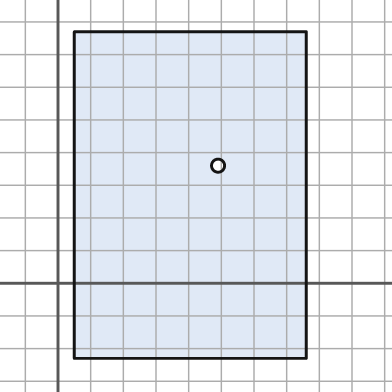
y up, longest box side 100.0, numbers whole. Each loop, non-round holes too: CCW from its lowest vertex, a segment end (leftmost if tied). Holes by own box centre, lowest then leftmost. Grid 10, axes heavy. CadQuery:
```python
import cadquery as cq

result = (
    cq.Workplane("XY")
    .moveTo(5.0, -23.0)
    .lineTo(76.0, -23.0)
    .lineTo(76.0, 77.0)
    .lineTo(5.0, 77.0)
    .close()
    .moveTo(49.0, 36.0)
    .circle(2.0)
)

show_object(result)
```